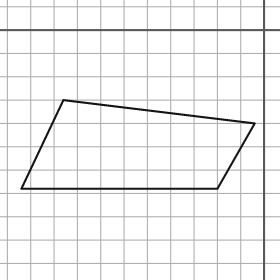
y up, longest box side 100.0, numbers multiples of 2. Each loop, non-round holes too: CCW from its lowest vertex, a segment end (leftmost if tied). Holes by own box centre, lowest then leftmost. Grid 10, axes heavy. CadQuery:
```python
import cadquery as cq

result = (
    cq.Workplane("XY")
    .moveTo(-104.0, -68.0)
    .lineTo(-20.0, -68.0)
    .lineTo(-4.0, -40.0)
    .lineTo(-86.0, -30.0)
    .close()
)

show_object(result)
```